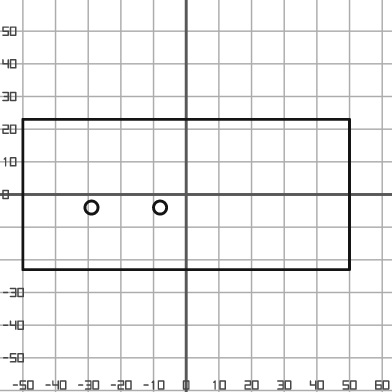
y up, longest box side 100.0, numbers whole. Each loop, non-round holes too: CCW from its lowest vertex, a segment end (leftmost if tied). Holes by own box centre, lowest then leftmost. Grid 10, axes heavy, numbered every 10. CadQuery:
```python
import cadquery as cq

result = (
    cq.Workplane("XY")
    .moveTo(-50.0, -23.0)
    .lineTo(50.0, -23.0)
    .lineTo(50.0, 23.0)
    .lineTo(-50.0, 23.0)
    .close()
    .moveTo(-29.0, -4.0)
    .circle(2.0)
    .moveTo(-8.0, -4.0)
    .circle(2.0)
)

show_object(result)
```